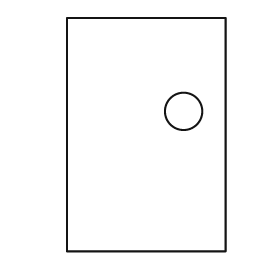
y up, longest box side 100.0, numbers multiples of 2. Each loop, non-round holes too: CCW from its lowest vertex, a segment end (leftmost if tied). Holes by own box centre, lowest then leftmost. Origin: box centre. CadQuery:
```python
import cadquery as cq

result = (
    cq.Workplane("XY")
    .moveTo(-34.0, -50.0)
    .lineTo(34.0, -50.0)
    .lineTo(34.0, 50.0)
    .lineTo(-34.0, 50.0)
    .close()
    .moveTo(16.0, 10.0)
    .circle(8.0)
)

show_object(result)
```